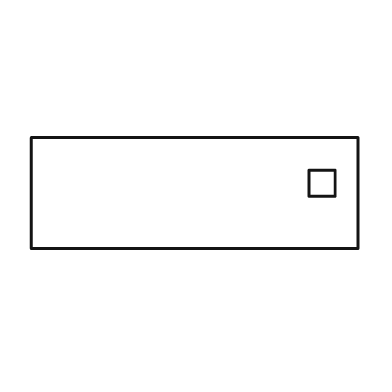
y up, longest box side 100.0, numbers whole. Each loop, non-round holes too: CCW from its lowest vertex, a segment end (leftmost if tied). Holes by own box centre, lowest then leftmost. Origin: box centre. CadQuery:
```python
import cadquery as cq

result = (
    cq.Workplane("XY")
    .moveTo(-50.0, -17.0)
    .lineTo(50.0, -17.0)
    .lineTo(50.0, 17.0)
    .lineTo(-50.0, 17.0)
    .close()
    .moveTo(35.0, -1.0)
    .lineTo(43.0, -1.0)
    .lineTo(43.0, 7.0)
    .lineTo(35.0, 7.0)
    .close()
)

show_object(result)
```